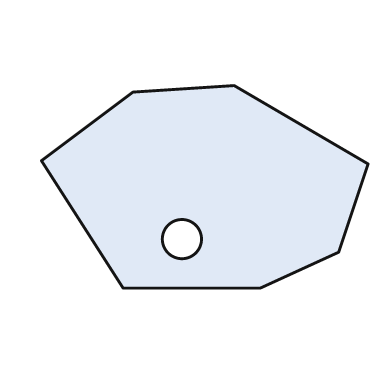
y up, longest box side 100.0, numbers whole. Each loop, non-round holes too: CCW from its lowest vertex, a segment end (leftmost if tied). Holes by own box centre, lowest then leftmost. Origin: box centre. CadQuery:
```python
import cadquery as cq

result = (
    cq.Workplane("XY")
    .moveTo(-25.0, -31.0)
    .lineTo(17.0, -31.0)
    .lineTo(41.0, -20.0)
    .lineTo(50.0, 7.0)
    .lineTo(9.0, 31.0)
    .lineTo(-22.0, 29.0)
    .lineTo(-50.0, 8.0)
    .close()
    .moveTo(-7.0, -16.0)
    .circle(6.0)
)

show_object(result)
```